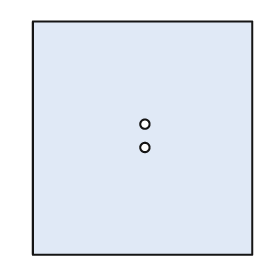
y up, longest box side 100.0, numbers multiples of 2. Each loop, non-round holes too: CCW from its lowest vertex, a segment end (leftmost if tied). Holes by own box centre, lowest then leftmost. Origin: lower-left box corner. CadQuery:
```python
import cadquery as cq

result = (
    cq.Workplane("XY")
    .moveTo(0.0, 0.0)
    .lineTo(94.0, 0.0)
    .lineTo(94.0, 100.0)
    .lineTo(0.0, 100.0)
    .close()
    .moveTo(48.0, 46.0)
    .circle(2.0)
    .moveTo(48.0, 56.0)
    .circle(2.0)
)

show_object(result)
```